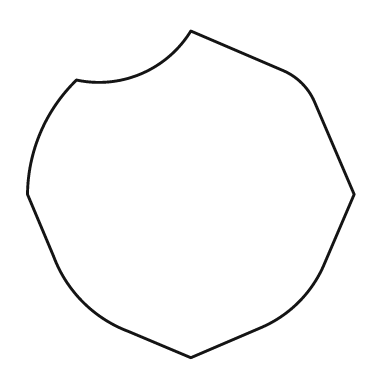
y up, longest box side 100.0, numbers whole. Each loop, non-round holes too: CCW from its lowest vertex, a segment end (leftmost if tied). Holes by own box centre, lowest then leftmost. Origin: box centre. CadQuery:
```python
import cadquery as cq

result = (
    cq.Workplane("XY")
    .moveTo(0.0, -50.0)
    .lineTo(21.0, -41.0)
    .threePointArc((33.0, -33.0), (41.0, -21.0))
    .lineTo(50.0, 0.0)
    .lineTo(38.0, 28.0)
    .threePointArc((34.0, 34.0), (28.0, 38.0))
    .lineTo(0.0, 50.0)
    .threePointArc((-15.0, 37.0), (-35.0, 35.0))
    .threePointArc((-46.0, 19.0), (-50.0, 0.0))
    .lineTo(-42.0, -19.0)
    .threePointArc((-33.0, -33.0), (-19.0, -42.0))
    .close()
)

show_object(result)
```